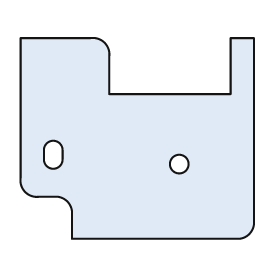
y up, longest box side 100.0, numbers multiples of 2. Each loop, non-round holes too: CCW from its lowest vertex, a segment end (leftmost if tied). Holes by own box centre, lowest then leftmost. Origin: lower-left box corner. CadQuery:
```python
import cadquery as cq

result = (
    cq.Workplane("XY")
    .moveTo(22.0, 0.0)
    .lineTo(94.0, 0.0)
    .threePointArc((98.0, 2.0), (100.0, 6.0))
    .lineTo(100.0, 86.0)
    .lineTo(90.0, 86.0)
    .lineTo(90.0, 62.0)
    .lineTo(38.0, 62.0)
    .lineTo(38.0, 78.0)
    .threePointArc((36.0, 84.0), (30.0, 86.0))
    .lineTo(0.0, 86.0)
    .lineTo(0.0, 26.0)
    .threePointArc((2.0, 20.0), (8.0, 18.0))
    .lineTo(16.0, 18.0)
    .threePointArc((20.0, 16.0), (22.0, 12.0))
    .close()
    .moveTo(68.0, 32.0)
    .circle(4.0)
    .moveTo(10.0, 34.0)
    .threePointArc((14.0, 30.0), (18.0, 34.0))
    .lineTo(18.0, 38.0)
    .threePointArc((14.0, 42.0), (10.0, 38.0))
    .close()
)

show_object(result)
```